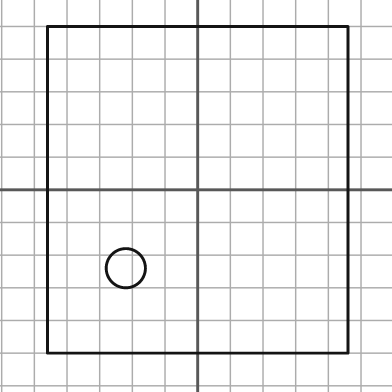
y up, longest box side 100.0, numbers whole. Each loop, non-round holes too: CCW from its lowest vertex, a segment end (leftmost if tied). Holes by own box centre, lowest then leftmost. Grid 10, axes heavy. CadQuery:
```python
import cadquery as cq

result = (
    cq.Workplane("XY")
    .moveTo(-46.0, -50.0)
    .lineTo(46.0, -50.0)
    .lineTo(46.0, 50.0)
    .lineTo(-46.0, 50.0)
    .close()
    .moveTo(-22.0, -24.0)
    .circle(6.0)
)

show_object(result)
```